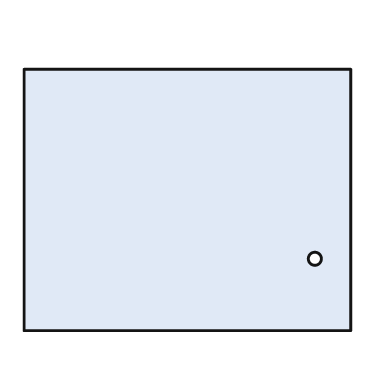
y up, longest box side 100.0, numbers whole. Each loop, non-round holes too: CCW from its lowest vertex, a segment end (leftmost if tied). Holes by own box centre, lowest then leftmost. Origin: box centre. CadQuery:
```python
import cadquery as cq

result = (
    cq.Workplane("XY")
    .moveTo(-50.0, -40.0)
    .lineTo(50.0, -40.0)
    .lineTo(50.0, 40.0)
    .lineTo(-50.0, 40.0)
    .close()
    .moveTo(39.0, -18.0)
    .circle(2.0)
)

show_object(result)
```